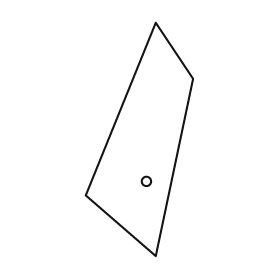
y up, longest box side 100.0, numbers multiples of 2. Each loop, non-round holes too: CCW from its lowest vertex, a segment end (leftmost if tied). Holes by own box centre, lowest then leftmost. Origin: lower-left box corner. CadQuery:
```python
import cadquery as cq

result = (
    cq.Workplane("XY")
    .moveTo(30.0, 0.0)
    .lineTo(46.0, 76.0)
    .lineTo(30.0, 100.0)
    .lineTo(0.0, 26.0)
    .close()
    .moveTo(26.0, 32.0)
    .circle(2.0)
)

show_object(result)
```